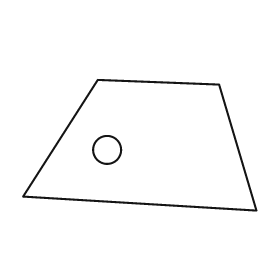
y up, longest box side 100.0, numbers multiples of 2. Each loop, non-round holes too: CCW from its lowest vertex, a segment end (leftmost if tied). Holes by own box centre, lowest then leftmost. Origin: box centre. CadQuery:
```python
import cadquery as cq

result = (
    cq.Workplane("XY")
    .moveTo(50.0, -28.0)
    .lineTo(34.0, 26.0)
    .lineTo(-18.0, 28.0)
    .lineTo(-50.0, -22.0)
    .close()
    .moveTo(-14.0, -2.0)
    .circle(6.0)
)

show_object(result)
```